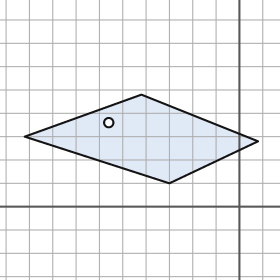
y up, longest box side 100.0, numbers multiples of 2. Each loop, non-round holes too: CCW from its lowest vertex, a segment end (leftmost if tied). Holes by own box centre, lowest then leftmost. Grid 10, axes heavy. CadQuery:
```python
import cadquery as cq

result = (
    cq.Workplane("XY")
    .moveTo(-30.0, 10.0)
    .lineTo(8.0, 28.0)
    .lineTo(-42.0, 48.0)
    .lineTo(-92.0, 30.0)
    .close()
    .moveTo(-56.0, 36.0)
    .circle(2.0)
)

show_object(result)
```